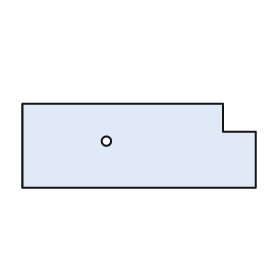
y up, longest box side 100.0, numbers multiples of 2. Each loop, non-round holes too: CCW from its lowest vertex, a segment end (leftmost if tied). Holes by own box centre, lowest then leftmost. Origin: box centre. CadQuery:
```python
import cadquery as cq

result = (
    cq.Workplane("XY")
    .moveTo(-50.0, -18.0)
    .lineTo(50.0, -18.0)
    .lineTo(50.0, 6.0)
    .lineTo(36.0, 6.0)
    .lineTo(36.0, 18.0)
    .lineTo(-50.0, 18.0)
    .close()
    .moveTo(-14.0, 2.0)
    .circle(2.0)
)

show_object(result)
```